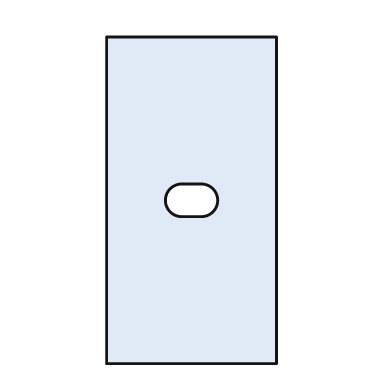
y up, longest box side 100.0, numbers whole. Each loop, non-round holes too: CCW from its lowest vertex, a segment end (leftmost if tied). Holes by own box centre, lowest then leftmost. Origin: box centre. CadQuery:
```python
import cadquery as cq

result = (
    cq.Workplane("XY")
    .moveTo(-26.0, -50.0)
    .lineTo(26.0, -50.0)
    .lineTo(26.0, 50.0)
    .lineTo(-26.0, 50.0)
    .close()
    .moveTo(-3.0, -5.0)
    .lineTo(3.0, -5.0)
    .threePointArc((8.0, 0.0), (3.0, 5.0))
    .lineTo(-3.0, 5.0)
    .threePointArc((-8.0, 0.0), (-3.0, -5.0))
    .close()
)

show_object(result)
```